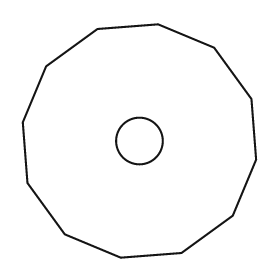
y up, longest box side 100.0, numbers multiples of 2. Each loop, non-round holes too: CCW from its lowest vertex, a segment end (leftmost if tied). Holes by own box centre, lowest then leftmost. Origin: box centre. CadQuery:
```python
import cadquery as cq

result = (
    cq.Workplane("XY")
    .moveTo(-8.0, -50.0)
    .lineTo(18.0, -48.0)
    .lineTo(40.0, -32.0)
    .lineTo(50.0, -8.0)
    .lineTo(48.0, 18.0)
    .lineTo(32.0, 40.0)
    .lineTo(8.0, 50.0)
    .lineTo(-18.0, 48.0)
    .lineTo(-40.0, 32.0)
    .lineTo(-50.0, 8.0)
    .lineTo(-48.0, -18.0)
    .lineTo(-32.0, -40.0)
    .close()
    .moveTo(0.0, 0.0)
    .circle(10.0)
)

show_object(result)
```